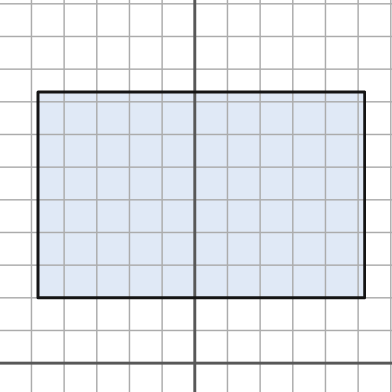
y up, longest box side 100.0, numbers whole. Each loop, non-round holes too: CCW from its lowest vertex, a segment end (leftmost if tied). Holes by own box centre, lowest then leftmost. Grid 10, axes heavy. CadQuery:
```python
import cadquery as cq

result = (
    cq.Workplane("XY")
    .moveTo(-48.0, 20.0)
    .lineTo(52.0, 20.0)
    .lineTo(52.0, 83.0)
    .lineTo(-48.0, 83.0)
    .close()
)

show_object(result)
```